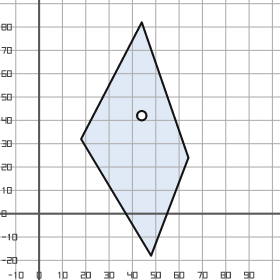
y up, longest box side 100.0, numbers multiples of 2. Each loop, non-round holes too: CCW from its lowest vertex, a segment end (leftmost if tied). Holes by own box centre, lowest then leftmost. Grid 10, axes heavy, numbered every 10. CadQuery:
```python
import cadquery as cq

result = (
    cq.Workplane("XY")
    .moveTo(48.0, -18.0)
    .lineTo(64.0, 24.0)
    .lineTo(44.0, 82.0)
    .lineTo(18.0, 32.0)
    .close()
    .moveTo(44.0, 42.0)
    .circle(2.0)
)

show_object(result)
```